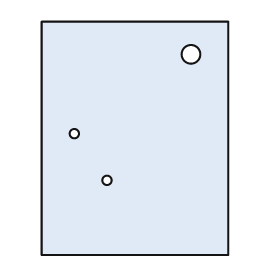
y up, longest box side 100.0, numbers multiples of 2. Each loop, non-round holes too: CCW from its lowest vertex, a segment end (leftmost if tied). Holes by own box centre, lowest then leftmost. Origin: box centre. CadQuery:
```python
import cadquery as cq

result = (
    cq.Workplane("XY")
    .moveTo(-40.0, -50.0)
    .lineTo(40.0, -50.0)
    .lineTo(40.0, 50.0)
    .lineTo(-40.0, 50.0)
    .close()
    .moveTo(-12.0, -18.0)
    .circle(2.0)
    .moveTo(-26.0, 2.0)
    .circle(2.0)
    .moveTo(24.0, 36.0)
    .circle(4.0)
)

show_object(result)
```